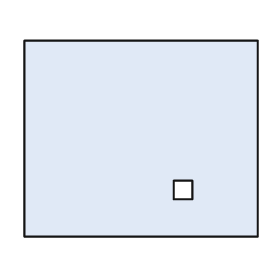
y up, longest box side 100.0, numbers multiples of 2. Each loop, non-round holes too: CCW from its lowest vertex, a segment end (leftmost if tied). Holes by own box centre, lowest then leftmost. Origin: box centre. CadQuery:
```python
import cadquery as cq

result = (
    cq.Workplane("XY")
    .moveTo(-50.0, -42.0)
    .lineTo(50.0, -42.0)
    .lineTo(50.0, 42.0)
    .lineTo(-50.0, 42.0)
    .close()
    .moveTo(14.0, -26.0)
    .lineTo(22.0, -26.0)
    .lineTo(22.0, -18.0)
    .lineTo(14.0, -18.0)
    .close()
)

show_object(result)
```